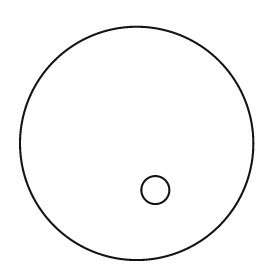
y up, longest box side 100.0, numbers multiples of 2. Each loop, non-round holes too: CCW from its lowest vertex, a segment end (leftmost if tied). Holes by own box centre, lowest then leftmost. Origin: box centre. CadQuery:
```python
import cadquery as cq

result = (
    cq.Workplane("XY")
    .moveTo(0.0, 0.0)
    .circle(50.0)
    .moveTo(8.0, -20.0)
    .circle(6.0)
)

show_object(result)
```